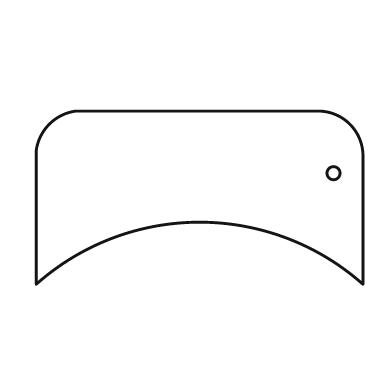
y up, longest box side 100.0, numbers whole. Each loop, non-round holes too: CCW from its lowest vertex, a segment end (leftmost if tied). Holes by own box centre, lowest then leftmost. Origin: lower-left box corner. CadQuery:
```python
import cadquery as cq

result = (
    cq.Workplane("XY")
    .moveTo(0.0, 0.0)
    .threePointArc((50.0, 19.0), (100.0, 0.0))
    .lineTo(100.0, 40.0)
    .threePointArc((96.0, 49.0), (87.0, 53.0))
    .lineTo(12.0, 53.0)
    .threePointArc((4.0, 49.0), (0.0, 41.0))
    .close()
    .moveTo(91.0, 34.0)
    .circle(2.0)
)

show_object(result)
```